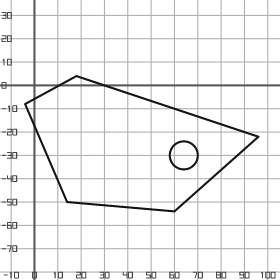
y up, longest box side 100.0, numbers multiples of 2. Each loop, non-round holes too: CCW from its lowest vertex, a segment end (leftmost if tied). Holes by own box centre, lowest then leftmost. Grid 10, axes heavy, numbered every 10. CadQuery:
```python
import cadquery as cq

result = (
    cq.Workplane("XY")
    .moveTo(60.0, -54.0)
    .lineTo(96.0, -22.0)
    .lineTo(18.0, 4.0)
    .lineTo(-4.0, -8.0)
    .lineTo(14.0, -50.0)
    .close()
    .moveTo(64.0, -30.0)
    .circle(6.0)
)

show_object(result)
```